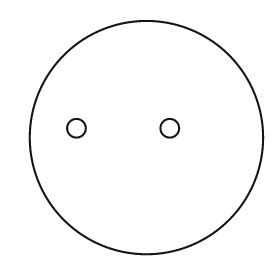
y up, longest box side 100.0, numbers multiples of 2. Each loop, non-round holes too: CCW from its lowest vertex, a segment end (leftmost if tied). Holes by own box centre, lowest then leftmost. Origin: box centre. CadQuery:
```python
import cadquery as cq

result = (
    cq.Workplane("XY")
    .moveTo(0.0, 0.0)
    .circle(50.0)
    .moveTo(-30.0, 4.0)
    .circle(4.0)
    .moveTo(10.0, 4.0)
    .circle(4.0)
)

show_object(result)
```